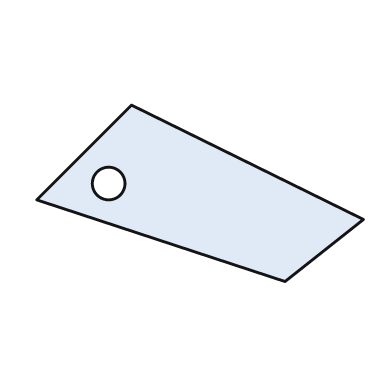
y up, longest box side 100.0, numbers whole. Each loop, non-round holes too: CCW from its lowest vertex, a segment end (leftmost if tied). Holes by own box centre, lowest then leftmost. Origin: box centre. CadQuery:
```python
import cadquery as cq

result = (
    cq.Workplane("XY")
    .moveTo(26.0, -27.0)
    .lineTo(50.0, -8.0)
    .lineTo(-21.0, 27.0)
    .lineTo(-50.0, -2.0)
    .close()
    .moveTo(-28.0, 3.0)
    .circle(5.0)
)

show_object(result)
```